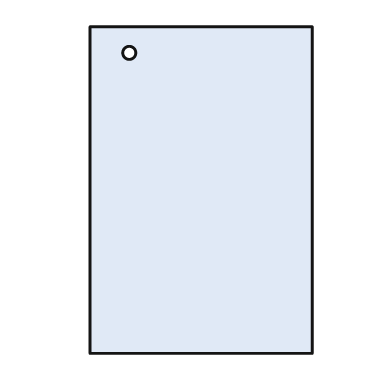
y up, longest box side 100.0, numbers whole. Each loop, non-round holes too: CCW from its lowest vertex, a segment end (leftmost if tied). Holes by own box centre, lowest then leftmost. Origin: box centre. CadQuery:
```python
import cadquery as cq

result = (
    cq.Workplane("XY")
    .moveTo(-34.0, -50.0)
    .lineTo(34.0, -50.0)
    .lineTo(34.0, 50.0)
    .lineTo(-34.0, 50.0)
    .close()
    .moveTo(-22.0, 42.0)
    .circle(2.0)
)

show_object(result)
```